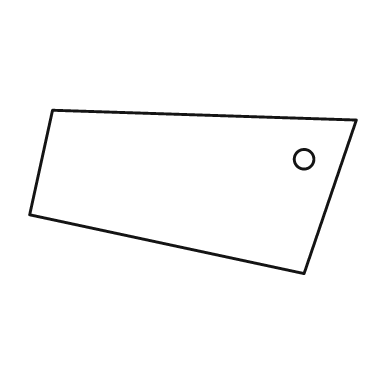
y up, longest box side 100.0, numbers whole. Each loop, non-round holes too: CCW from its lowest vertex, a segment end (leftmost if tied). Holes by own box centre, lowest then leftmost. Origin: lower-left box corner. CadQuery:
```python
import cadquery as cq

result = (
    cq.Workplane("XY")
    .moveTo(84.0, 0.0)
    .lineTo(100.0, 47.0)
    .lineTo(7.0, 50.0)
    .lineTo(0.0, 18.0)
    .close()
    .moveTo(84.0, 35.0)
    .circle(3.0)
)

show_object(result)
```